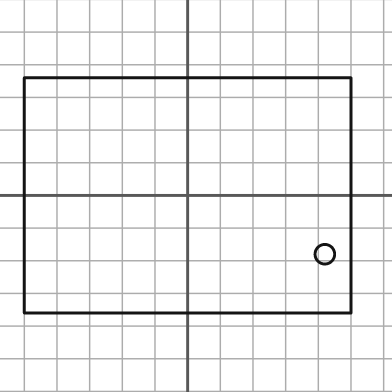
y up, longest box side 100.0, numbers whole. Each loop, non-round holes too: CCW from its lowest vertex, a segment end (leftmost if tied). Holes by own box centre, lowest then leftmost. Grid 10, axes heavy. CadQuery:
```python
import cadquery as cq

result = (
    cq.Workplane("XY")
    .moveTo(-50.0, -36.0)
    .lineTo(50.0, -36.0)
    .lineTo(50.0, 36.0)
    .lineTo(-50.0, 36.0)
    .close()
    .moveTo(42.0, -18.0)
    .circle(3.0)
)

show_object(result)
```